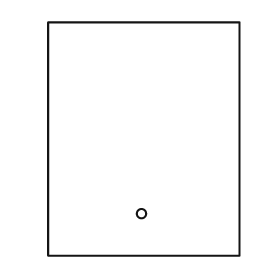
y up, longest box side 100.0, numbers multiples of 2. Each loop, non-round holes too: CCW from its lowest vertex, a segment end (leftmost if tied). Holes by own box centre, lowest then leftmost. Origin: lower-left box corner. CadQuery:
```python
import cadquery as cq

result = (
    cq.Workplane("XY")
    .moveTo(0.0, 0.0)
    .lineTo(82.0, 0.0)
    .lineTo(82.0, 100.0)
    .lineTo(0.0, 100.0)
    .close()
    .moveTo(40.0, 18.0)
    .circle(2.0)
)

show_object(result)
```